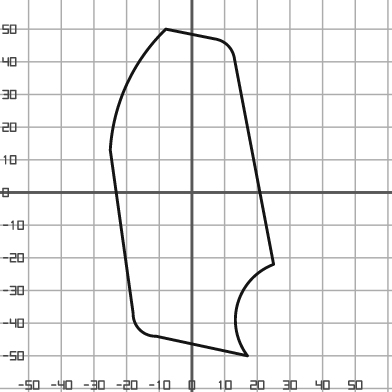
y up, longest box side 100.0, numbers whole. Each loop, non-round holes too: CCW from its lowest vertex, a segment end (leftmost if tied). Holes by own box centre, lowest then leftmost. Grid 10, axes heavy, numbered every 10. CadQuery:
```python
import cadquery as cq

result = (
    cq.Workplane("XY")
    .moveTo(17.0, -50.0)
    .threePointArc((14.0, -34.0), (25.0, -22.0))
    .lineTo(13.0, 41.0)
    .threePointArc((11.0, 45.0), (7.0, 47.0))
    .lineTo(-8.0, 50.0)
    .threePointArc((-20.0, 33.0), (-25.0, 13.0))
    .lineTo(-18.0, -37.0)
    .threePointArc((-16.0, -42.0), (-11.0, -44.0))
    .close()
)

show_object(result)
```